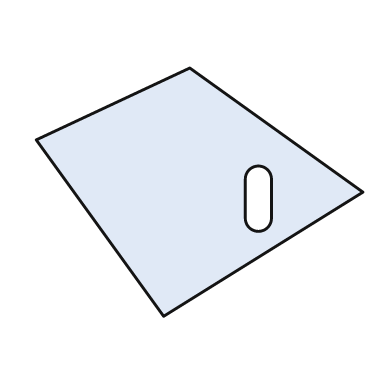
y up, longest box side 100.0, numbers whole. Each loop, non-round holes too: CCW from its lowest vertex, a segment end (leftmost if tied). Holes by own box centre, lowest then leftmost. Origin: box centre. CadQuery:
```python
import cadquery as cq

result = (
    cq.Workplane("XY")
    .moveTo(-11.0, -38.0)
    .lineTo(50.0, 0.0)
    .lineTo(-3.0, 38.0)
    .lineTo(-50.0, 16.0)
    .close()
    .moveTo(14.0, -8.0)
    .threePointArc((18.0, -12.0), (22.0, -8.0))
    .lineTo(22.0, 4.0)
    .threePointArc((18.0, 8.0), (14.0, 4.0))
    .close()
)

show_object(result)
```